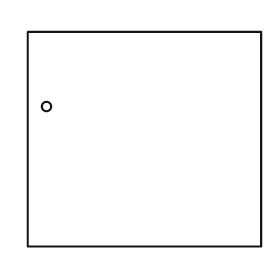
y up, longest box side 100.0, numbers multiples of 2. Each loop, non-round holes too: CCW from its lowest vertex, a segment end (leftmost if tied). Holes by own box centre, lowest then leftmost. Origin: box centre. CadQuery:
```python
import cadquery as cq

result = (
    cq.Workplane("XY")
    .moveTo(-50.0, -46.0)
    .lineTo(50.0, -46.0)
    .lineTo(50.0, 46.0)
    .lineTo(-50.0, 46.0)
    .close()
    .moveTo(-42.0, 14.0)
    .circle(2.0)
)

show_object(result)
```